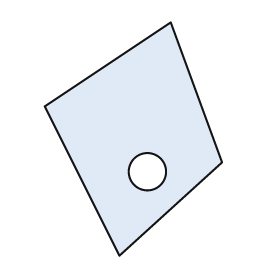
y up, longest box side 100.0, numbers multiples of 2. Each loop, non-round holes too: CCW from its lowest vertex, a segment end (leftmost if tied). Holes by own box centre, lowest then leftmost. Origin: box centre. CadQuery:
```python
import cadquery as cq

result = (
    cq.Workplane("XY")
    .moveTo(-6.0, -50.0)
    .lineTo(38.0, -10.0)
    .lineTo(16.0, 50.0)
    .lineTo(-38.0, 14.0)
    .close()
    .moveTo(6.0, -14.0)
    .circle(8.0)
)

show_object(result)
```